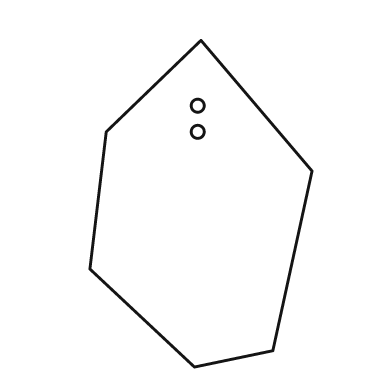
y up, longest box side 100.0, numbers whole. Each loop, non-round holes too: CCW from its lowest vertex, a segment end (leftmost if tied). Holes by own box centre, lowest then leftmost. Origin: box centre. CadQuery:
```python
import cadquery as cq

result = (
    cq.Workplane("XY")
    .moveTo(-2.0, -50.0)
    .lineTo(22.0, -45.0)
    .lineTo(34.0, 10.0)
    .lineTo(0.0, 50.0)
    .lineTo(-29.0, 22.0)
    .lineTo(-34.0, -20.0)
    .close()
    .moveTo(-1.0, 22.0)
    .circle(2.0)
    .moveTo(-1.0, 30.0)
    .circle(2.0)
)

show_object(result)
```